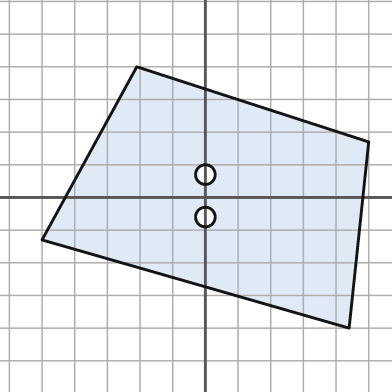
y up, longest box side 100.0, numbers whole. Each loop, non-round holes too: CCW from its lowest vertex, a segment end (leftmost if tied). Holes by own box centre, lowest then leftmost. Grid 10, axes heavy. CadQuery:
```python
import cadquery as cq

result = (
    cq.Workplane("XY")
    .moveTo(44.0, -40.0)
    .lineTo(50.0, 17.0)
    .lineTo(-21.0, 40.0)
    .lineTo(-50.0, -13.0)
    .close()
    .moveTo(0.0, -6.0)
    .circle(3.0)
    .moveTo(0.0, 7.0)
    .circle(3.0)
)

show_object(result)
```